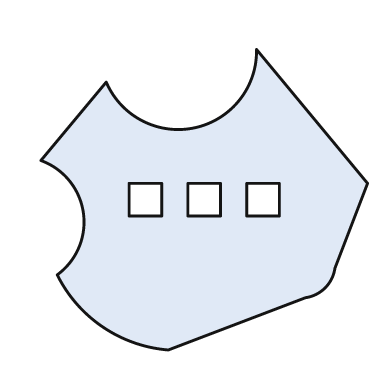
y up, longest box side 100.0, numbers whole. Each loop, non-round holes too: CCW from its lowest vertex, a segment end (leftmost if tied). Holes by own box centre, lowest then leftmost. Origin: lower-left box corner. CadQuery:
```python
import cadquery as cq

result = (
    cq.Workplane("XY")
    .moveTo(39.0, 0.0)
    .lineTo(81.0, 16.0)
    .threePointArc((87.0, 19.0), (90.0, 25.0))
    .lineTo(100.0, 51.0)
    .lineTo(66.0, 92.0)
    .threePointArc((47.0, 68.0), (20.0, 82.0))
    .lineTo(0.0, 58.0)
    .threePointArc((13.0, 42.0), (5.0, 23.0))
    .threePointArc((19.0, 7.0), (39.0, 0.0))
    .close()
    .moveTo(27.0, 41.0)
    .lineTo(37.0, 41.0)
    .lineTo(37.0, 51.0)
    .lineTo(27.0, 51.0)
    .close()
    .moveTo(45.0, 41.0)
    .lineTo(55.0, 41.0)
    .lineTo(55.0, 51.0)
    .lineTo(45.0, 51.0)
    .close()
    .moveTo(63.0, 41.0)
    .lineTo(73.0, 41.0)
    .lineTo(73.0, 51.0)
    .lineTo(63.0, 51.0)
    .close()
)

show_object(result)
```